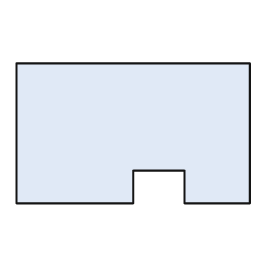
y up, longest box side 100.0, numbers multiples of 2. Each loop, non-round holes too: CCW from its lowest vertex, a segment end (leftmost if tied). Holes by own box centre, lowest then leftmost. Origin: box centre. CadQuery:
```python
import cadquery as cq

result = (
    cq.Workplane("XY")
    .moveTo(-50.0, -30.0)
    .lineTo(0.0, -30.0)
    .lineTo(0.0, -16.0)
    .lineTo(22.0, -16.0)
    .lineTo(22.0, -30.0)
    .lineTo(50.0, -30.0)
    .lineTo(50.0, 30.0)
    .lineTo(-50.0, 30.0)
    .close()
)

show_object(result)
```